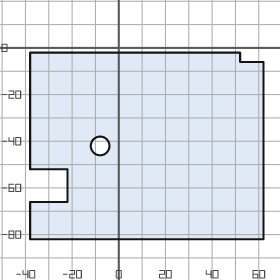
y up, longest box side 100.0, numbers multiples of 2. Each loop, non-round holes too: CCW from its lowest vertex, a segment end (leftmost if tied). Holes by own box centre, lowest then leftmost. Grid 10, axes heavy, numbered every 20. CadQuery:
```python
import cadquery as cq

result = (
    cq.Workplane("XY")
    .moveTo(-38.0, -82.0)
    .lineTo(62.0, -82.0)
    .lineTo(62.0, -6.0)
    .lineTo(52.0, -6.0)
    .lineTo(52.0, -2.0)
    .lineTo(-38.0, -2.0)
    .lineTo(-38.0, -52.0)
    .lineTo(-22.0, -52.0)
    .lineTo(-22.0, -66.0)
    .lineTo(-38.0, -66.0)
    .close()
    .moveTo(-8.0, -42.0)
    .circle(4.0)
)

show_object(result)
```